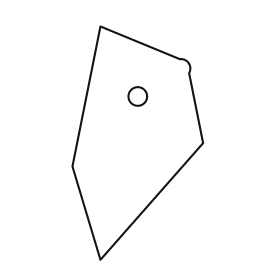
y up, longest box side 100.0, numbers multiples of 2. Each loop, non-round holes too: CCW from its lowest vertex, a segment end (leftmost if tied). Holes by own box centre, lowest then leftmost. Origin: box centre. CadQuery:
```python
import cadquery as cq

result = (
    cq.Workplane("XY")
    .moveTo(-16.0, -50.0)
    .lineTo(28.0, 0.0)
    .lineTo(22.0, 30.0)
    .threePointArc((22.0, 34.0), (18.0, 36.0))
    .lineTo(-16.0, 50.0)
    .lineTo(-28.0, -10.0)
    .close()
    .moveTo(0.0, 20.0)
    .circle(4.0)
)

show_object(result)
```